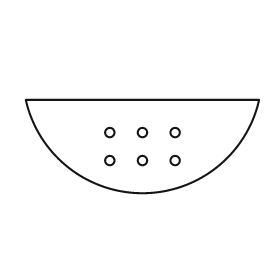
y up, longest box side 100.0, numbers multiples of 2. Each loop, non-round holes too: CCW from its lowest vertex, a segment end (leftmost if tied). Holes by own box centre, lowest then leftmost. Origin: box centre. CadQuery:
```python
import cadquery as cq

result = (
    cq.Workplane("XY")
    .moveTo(-50.0, 20.0)
    .threePointArc((0.0, -20.0), (50.0, 20.0))
    .close()
    .moveTo(-14.0, -6.0)
    .circle(2.0)
    .moveTo(0.0, -6.0)
    .circle(2.0)
    .moveTo(14.0, -6.0)
    .circle(2.0)
    .moveTo(-14.0, 6.0)
    .circle(2.0)
    .moveTo(0.0, 6.0)
    .circle(2.0)
    .moveTo(14.0, 6.0)
    .circle(2.0)
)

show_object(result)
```